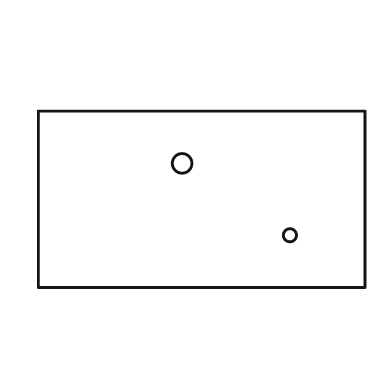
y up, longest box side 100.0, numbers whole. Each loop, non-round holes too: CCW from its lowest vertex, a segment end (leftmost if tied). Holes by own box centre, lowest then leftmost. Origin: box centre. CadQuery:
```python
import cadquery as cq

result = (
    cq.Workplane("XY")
    .moveTo(-50.0, -27.0)
    .lineTo(50.0, -27.0)
    .lineTo(50.0, 27.0)
    .lineTo(-50.0, 27.0)
    .close()
    .moveTo(27.0, -11.0)
    .circle(2.0)
    .moveTo(-6.0, 11.0)
    .circle(3.0)
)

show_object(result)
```